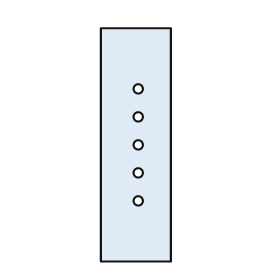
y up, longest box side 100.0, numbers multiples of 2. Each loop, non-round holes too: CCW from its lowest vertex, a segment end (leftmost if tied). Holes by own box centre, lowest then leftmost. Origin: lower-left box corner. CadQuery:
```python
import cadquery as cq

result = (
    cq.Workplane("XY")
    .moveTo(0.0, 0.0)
    .lineTo(30.0, 0.0)
    .lineTo(30.0, 100.0)
    .lineTo(0.0, 100.0)
    .close()
    .moveTo(16.0, 26.0)
    .circle(2.0)
    .moveTo(16.0, 38.0)
    .circle(2.0)
    .moveTo(16.0, 50.0)
    .circle(2.0)
    .moveTo(16.0, 62.0)
    .circle(2.0)
    .moveTo(16.0, 74.0)
    .circle(2.0)
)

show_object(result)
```